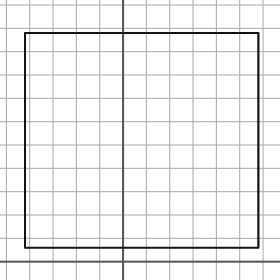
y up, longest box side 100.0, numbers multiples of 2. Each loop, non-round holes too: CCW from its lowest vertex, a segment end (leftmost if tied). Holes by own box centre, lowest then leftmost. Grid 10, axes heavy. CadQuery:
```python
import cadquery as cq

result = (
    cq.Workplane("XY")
    .moveTo(-42.0, 6.0)
    .lineTo(58.0, 6.0)
    .lineTo(58.0, 98.0)
    .lineTo(-42.0, 98.0)
    .close()
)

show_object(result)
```